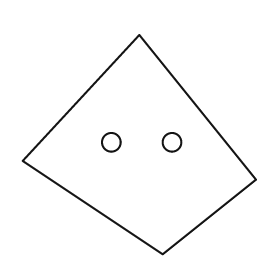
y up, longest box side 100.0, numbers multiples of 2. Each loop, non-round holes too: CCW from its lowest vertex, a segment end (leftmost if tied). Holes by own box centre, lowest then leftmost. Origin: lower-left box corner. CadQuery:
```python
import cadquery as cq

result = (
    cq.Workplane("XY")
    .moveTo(60.0, 0.0)
    .lineTo(100.0, 32.0)
    .lineTo(50.0, 94.0)
    .lineTo(0.0, 40.0)
    .close()
    .moveTo(38.0, 48.0)
    .circle(4.0)
    .moveTo(64.0, 48.0)
    .circle(4.0)
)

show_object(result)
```